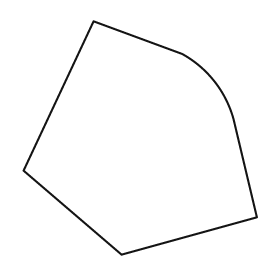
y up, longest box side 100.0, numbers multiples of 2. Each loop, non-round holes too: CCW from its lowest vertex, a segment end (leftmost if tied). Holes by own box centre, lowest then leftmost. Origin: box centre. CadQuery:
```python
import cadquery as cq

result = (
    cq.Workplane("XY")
    .moveTo(-8.0, -50.0)
    .lineTo(50.0, -34.0)
    .lineTo(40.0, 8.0)
    .threePointArc((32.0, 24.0), (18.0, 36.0))
    .lineTo(-20.0, 50.0)
    .lineTo(-50.0, -14.0)
    .close()
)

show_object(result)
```